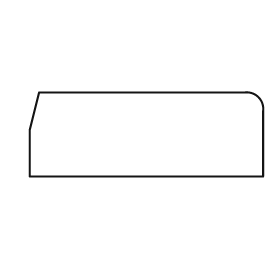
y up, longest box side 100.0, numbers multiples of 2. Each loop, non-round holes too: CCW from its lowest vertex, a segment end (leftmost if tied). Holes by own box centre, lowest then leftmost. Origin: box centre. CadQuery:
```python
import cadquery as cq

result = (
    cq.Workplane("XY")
    .moveTo(-50.0, -18.0)
    .lineTo(50.0, -18.0)
    .lineTo(50.0, 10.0)
    .threePointArc((48.0, 16.0), (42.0, 18.0))
    .lineTo(-46.0, 18.0)
    .lineTo(-50.0, 2.0)
    .close()
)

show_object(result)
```